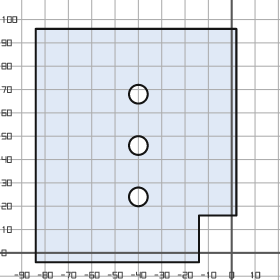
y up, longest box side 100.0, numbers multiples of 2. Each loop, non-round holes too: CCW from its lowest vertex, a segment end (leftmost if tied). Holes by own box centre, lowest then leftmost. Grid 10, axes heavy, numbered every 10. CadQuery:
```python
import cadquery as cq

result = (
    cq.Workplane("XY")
    .moveTo(-84.0, -4.0)
    .lineTo(-14.0, -4.0)
    .lineTo(-14.0, 16.0)
    .lineTo(2.0, 16.0)
    .lineTo(2.0, 96.0)
    .lineTo(-84.0, 96.0)
    .close()
    .moveTo(-40.0, 24.0)
    .circle(4.0)
    .moveTo(-40.0, 46.0)
    .circle(4.0)
    .moveTo(-40.0, 68.0)
    .circle(4.0)
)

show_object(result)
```